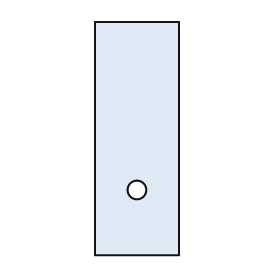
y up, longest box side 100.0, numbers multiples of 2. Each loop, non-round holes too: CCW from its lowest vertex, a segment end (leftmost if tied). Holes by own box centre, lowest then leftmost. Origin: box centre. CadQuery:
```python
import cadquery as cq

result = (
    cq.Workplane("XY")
    .moveTo(-18.0, -50.0)
    .lineTo(18.0, -50.0)
    .lineTo(18.0, 50.0)
    .lineTo(-18.0, 50.0)
    .close()
    .moveTo(0.0, -22.0)
    .circle(4.0)
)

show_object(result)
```